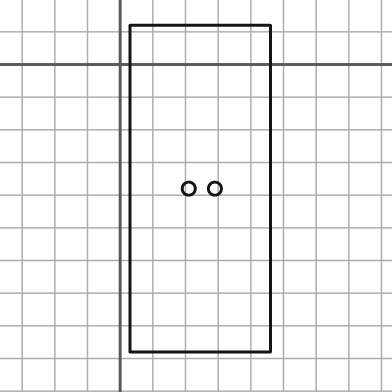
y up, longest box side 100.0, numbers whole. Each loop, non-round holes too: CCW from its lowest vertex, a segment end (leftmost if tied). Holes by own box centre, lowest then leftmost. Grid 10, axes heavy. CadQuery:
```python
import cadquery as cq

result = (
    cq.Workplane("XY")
    .moveTo(3.0, -88.0)
    .lineTo(46.0, -88.0)
    .lineTo(46.0, 12.0)
    .lineTo(3.0, 12.0)
    .close()
    .moveTo(21.0, -38.0)
    .circle(2.0)
    .moveTo(29.0, -38.0)
    .circle(2.0)
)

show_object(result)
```